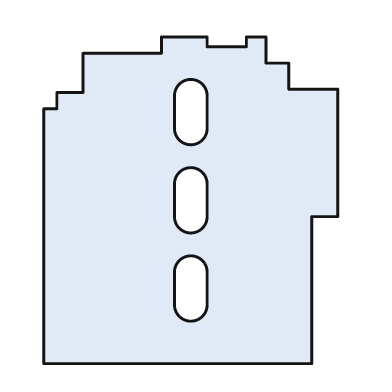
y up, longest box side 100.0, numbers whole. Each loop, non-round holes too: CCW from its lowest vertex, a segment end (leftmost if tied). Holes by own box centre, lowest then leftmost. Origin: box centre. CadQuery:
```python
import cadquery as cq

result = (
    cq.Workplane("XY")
    .moveTo(-45.0, -50.0)
    .lineTo(37.0, -50.0)
    .lineTo(37.0, -5.0)
    .lineTo(45.0, -5.0)
    .lineTo(45.0, 34.0)
    .lineTo(30.0, 34.0)
    .lineTo(30.0, 42.0)
    .lineTo(23.0, 42.0)
    .lineTo(23.0, 50.0)
    .lineTo(17.0, 50.0)
    .lineTo(17.0, 47.0)
    .lineTo(5.0, 47.0)
    .lineTo(5.0, 50.0)
    .lineTo(-9.0, 50.0)
    .lineTo(-9.0, 45.0)
    .lineTo(-33.0, 45.0)
    .lineTo(-33.0, 33.0)
    .lineTo(-41.0, 33.0)
    .lineTo(-41.0, 28.0)
    .lineTo(-45.0, 28.0)
    .close()
    .moveTo(-5.0, -32.0)
    .threePointArc((0.0, -37.0), (5.0, -32.0))
    .lineTo(5.0, -22.0)
    .threePointArc((0.0, -17.0), (-5.0, -22.0))
    .close()
    .moveTo(-5.0, -5.0)
    .threePointArc((0.0, -10.0), (5.0, -5.0))
    .lineTo(5.0, 5.0)
    .threePointArc((0.0, 10.0), (-5.0, 5.0))
    .close()
    .moveTo(-5.0, 22.0)
    .threePointArc((0.0, 17.0), (5.0, 22.0))
    .lineTo(5.0, 32.0)
    .threePointArc((0.0, 37.0), (-5.0, 32.0))
    .close()
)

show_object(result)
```